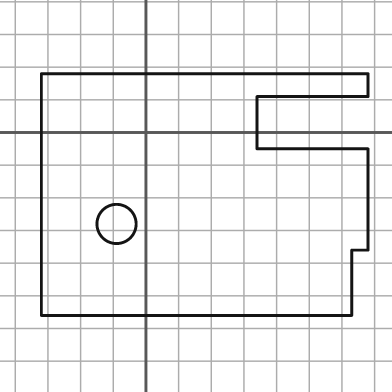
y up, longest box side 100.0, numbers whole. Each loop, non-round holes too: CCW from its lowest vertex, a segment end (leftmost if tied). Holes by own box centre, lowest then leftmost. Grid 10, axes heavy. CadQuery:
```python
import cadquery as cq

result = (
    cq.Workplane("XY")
    .moveTo(-32.0, -56.0)
    .lineTo(63.0, -56.0)
    .lineTo(63.0, -36.0)
    .lineTo(68.0, -36.0)
    .lineTo(68.0, -5.0)
    .lineTo(34.0, -5.0)
    .lineTo(34.0, 11.0)
    .lineTo(68.0, 11.0)
    .lineTo(68.0, 18.0)
    .lineTo(-32.0, 18.0)
    .close()
    .moveTo(-9.0, -28.0)
    .circle(6.0)
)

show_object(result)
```